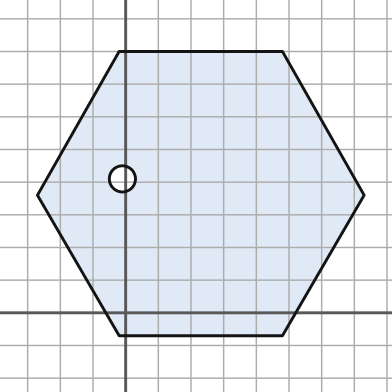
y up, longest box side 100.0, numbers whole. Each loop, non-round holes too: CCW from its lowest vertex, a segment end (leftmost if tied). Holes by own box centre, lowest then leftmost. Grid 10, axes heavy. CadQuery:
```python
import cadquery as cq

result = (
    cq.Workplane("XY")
    .moveTo(-2.0, -7.0)
    .lineTo(48.0, -7.0)
    .lineTo(73.0, 36.0)
    .lineTo(48.0, 80.0)
    .lineTo(-2.0, 80.0)
    .lineTo(-27.0, 36.0)
    .close()
    .moveTo(-1.0, 41.0)
    .circle(4.0)
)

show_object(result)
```